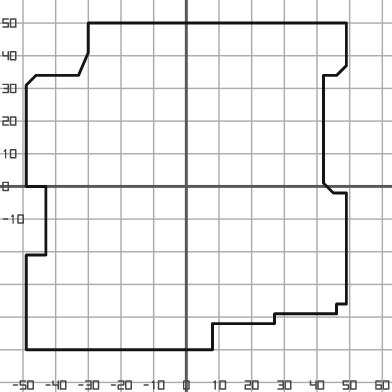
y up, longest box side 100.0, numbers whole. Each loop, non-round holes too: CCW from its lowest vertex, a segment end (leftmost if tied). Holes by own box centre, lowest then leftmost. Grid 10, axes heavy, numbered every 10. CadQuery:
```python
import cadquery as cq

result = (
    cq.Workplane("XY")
    .moveTo(-49.0, -50.0)
    .lineTo(8.0, -50.0)
    .lineTo(8.0, -42.0)
    .lineTo(27.0, -42.0)
    .lineTo(27.0, -39.0)
    .lineTo(46.0, -39.0)
    .lineTo(46.0, -36.0)
    .lineTo(49.0, -36.0)
    .lineTo(49.0, -2.0)
    .lineTo(45.0, -2.0)
    .lineTo(42.0, 1.0)
    .lineTo(42.0, 34.0)
    .lineTo(46.0, 34.0)
    .lineTo(49.0, 37.0)
    .lineTo(49.0, 50.0)
    .lineTo(-30.0, 50.0)
    .lineTo(-30.0, 41.0)
    .lineTo(-33.0, 34.0)
    .lineTo(-46.0, 34.0)
    .lineTo(-49.0, 31.0)
    .lineTo(-49.0, 0.0)
    .lineTo(-43.0, 0.0)
    .lineTo(-43.0, -21.0)
    .lineTo(-49.0, -21.0)
    .close()
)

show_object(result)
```